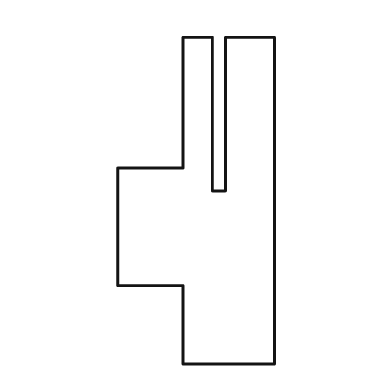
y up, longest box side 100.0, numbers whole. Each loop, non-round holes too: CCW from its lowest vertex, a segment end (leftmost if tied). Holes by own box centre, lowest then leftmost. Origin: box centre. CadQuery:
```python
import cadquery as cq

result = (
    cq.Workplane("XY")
    .moveTo(-4.0, -50.0)
    .lineTo(24.0, -50.0)
    .lineTo(24.0, 50.0)
    .lineTo(9.0, 50.0)
    .lineTo(9.0, 3.0)
    .lineTo(5.0, 3.0)
    .lineTo(5.0, 50.0)
    .lineTo(-4.0, 50.0)
    .lineTo(-4.0, 10.0)
    .lineTo(-24.0, 10.0)
    .lineTo(-24.0, -26.0)
    .lineTo(-4.0, -26.0)
    .close()
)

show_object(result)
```